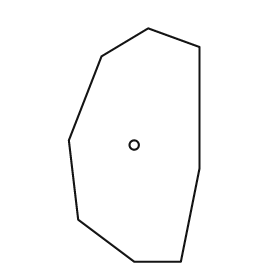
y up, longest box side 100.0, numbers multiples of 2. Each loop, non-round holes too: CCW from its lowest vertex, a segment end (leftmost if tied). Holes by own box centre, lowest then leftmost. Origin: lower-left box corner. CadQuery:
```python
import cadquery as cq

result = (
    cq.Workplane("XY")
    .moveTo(28.0, 0.0)
    .lineTo(48.0, 0.0)
    .lineTo(56.0, 40.0)
    .lineTo(56.0, 92.0)
    .lineTo(34.0, 100.0)
    .lineTo(14.0, 88.0)
    .lineTo(0.0, 52.0)
    .lineTo(4.0, 18.0)
    .close()
    .moveTo(28.0, 50.0)
    .circle(2.0)
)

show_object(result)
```